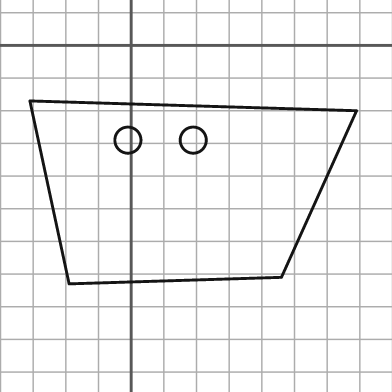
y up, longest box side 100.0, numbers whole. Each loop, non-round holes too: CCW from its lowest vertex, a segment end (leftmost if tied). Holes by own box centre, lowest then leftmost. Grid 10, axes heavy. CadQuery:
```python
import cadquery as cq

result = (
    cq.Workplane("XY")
    .moveTo(-19.0, -73.0)
    .lineTo(46.0, -71.0)
    .lineTo(69.0, -20.0)
    .lineTo(-31.0, -17.0)
    .close()
    .moveTo(-1.0, -29.0)
    .circle(4.0)
    .moveTo(19.0, -29.0)
    .circle(4.0)
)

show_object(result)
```